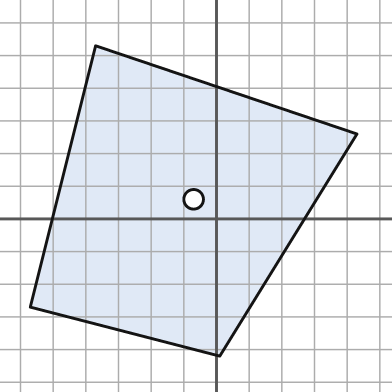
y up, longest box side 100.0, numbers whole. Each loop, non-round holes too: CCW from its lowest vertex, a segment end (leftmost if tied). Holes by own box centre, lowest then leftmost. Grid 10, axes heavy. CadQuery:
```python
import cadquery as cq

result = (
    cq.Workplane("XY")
    .moveTo(1.0, -42.0)
    .lineTo(43.0, 26.0)
    .lineTo(-37.0, 53.0)
    .lineTo(-57.0, -27.0)
    .close()
    .moveTo(-7.0, 6.0)
    .circle(3.0)
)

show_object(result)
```